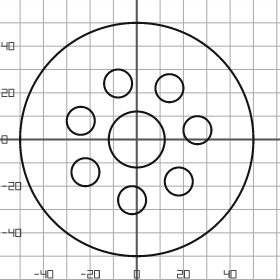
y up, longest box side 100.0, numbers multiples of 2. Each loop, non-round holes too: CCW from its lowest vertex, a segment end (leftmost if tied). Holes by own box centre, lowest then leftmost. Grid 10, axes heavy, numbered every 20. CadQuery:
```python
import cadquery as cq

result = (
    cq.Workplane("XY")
    .moveTo(0.0, 0.0)
    .circle(50.0)
    .moveTo(-2.0, -26.0)
    .circle(6.0)
    .moveTo(18.0, -18.0)
    .circle(6.0)
    .moveTo(-22.0, -14.0)
    .circle(6.0)
    .moveTo(0.0, 0.0)
    .circle(12.0)
    .moveTo(26.0, 4.0)
    .circle(6.0)
    .moveTo(-24.0, 8.0)
    .circle(6.0)
    .moveTo(14.0, 22.0)
    .circle(6.0)
    .moveTo(-8.0, 24.0)
    .circle(6.0)
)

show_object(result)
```